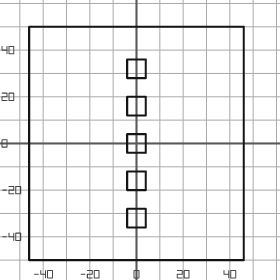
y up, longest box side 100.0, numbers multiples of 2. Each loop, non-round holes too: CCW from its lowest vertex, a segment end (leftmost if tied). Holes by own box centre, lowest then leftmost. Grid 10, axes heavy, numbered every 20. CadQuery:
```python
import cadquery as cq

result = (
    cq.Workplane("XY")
    .moveTo(-46.0, -50.0)
    .lineTo(46.0, -50.0)
    .lineTo(46.0, 50.0)
    .lineTo(-46.0, 50.0)
    .close()
    .moveTo(-4.0, -36.0)
    .lineTo(4.0, -36.0)
    .lineTo(4.0, -28.0)
    .lineTo(-4.0, -28.0)
    .close()
    .moveTo(-4.0, -20.0)
    .lineTo(4.0, -20.0)
    .lineTo(4.0, -12.0)
    .lineTo(-4.0, -12.0)
    .close()
    .moveTo(-4.0, -4.0)
    .lineTo(4.0, -4.0)
    .lineTo(4.0, 4.0)
    .lineTo(-4.0, 4.0)
    .close()
    .moveTo(-4.0, 12.0)
    .lineTo(4.0, 12.0)
    .lineTo(4.0, 20.0)
    .lineTo(-4.0, 20.0)
    .close()
    .moveTo(-4.0, 28.0)
    .lineTo(4.0, 28.0)
    .lineTo(4.0, 36.0)
    .lineTo(-4.0, 36.0)
    .close()
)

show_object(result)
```